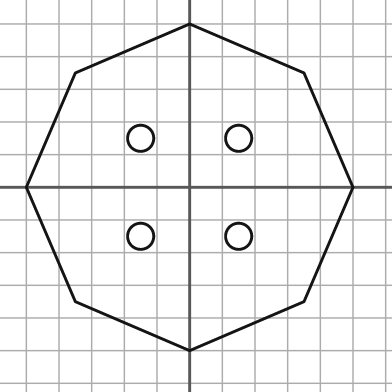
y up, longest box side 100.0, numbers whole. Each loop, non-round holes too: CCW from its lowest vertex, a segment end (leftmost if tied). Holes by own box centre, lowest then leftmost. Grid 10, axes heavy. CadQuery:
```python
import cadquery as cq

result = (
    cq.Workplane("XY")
    .moveTo(0.0, -50.0)
    .lineTo(35.0, -35.0)
    .lineTo(50.0, 0.0)
    .lineTo(35.0, 35.0)
    .lineTo(0.0, 50.0)
    .lineTo(-35.0, 35.0)
    .lineTo(-50.0, 0.0)
    .lineTo(-35.0, -35.0)
    .close()
    .moveTo(-15.0, -15.0)
    .circle(4.0)
    .moveTo(15.0, -15.0)
    .circle(4.0)
    .moveTo(-15.0, 15.0)
    .circle(4.0)
    .moveTo(15.0, 15.0)
    .circle(4.0)
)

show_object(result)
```